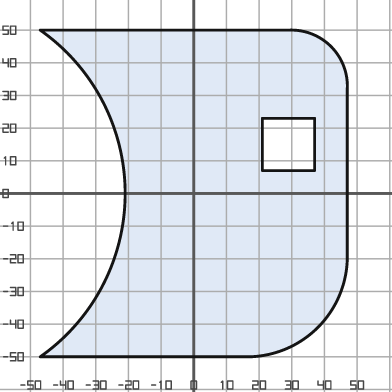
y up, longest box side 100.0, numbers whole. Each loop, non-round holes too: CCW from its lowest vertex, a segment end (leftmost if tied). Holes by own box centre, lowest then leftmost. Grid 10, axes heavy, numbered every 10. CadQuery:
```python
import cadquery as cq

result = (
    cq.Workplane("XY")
    .moveTo(-47.0, -50.0)
    .lineTo(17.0, -50.0)
    .threePointArc((38.0, -41.0), (47.0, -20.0))
    .lineTo(47.0, 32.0)
    .threePointArc((42.0, 45.0), (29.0, 50.0))
    .lineTo(-47.0, 50.0)
    .threePointArc((-21.0, 0.0), (-47.0, -50.0))
    .close()
    .moveTo(21.0, 7.0)
    .lineTo(37.0, 7.0)
    .lineTo(37.0, 23.0)
    .lineTo(21.0, 23.0)
    .close()
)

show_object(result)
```